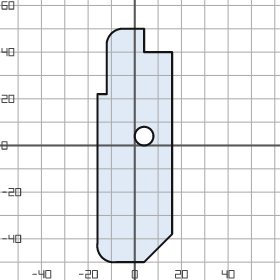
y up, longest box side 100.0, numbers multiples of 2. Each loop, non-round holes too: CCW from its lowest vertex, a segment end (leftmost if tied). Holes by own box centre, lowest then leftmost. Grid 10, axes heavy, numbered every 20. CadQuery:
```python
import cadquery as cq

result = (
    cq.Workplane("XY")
    .moveTo(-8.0, -50.0)
    .lineTo(4.0, -50.0)
    .lineTo(16.0, -38.0)
    .lineTo(16.0, 40.0)
    .lineTo(4.0, 40.0)
    .lineTo(4.0, 50.0)
    .lineTo(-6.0, 50.0)
    .threePointArc((-10.0, 48.0), (-12.0, 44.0))
    .lineTo(-12.0, 22.0)
    .lineTo(-16.0, 22.0)
    .lineTo(-16.0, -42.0)
    .threePointArc((-14.0, -48.0), (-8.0, -50.0))
    .close()
    .moveTo(4.0, 4.0)
    .circle(4.0)
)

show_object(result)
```